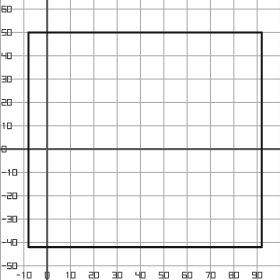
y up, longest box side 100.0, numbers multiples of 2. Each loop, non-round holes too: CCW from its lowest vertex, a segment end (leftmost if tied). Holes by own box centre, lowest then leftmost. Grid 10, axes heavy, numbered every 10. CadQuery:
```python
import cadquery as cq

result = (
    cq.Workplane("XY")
    .moveTo(-8.0, -42.0)
    .lineTo(92.0, -42.0)
    .lineTo(92.0, 50.0)
    .lineTo(-8.0, 50.0)
    .close()
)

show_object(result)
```